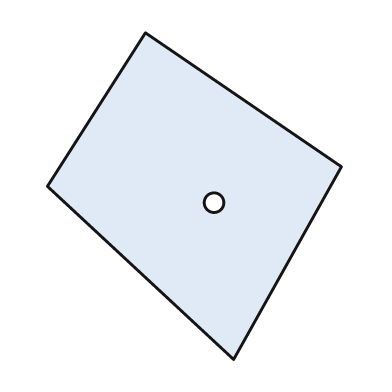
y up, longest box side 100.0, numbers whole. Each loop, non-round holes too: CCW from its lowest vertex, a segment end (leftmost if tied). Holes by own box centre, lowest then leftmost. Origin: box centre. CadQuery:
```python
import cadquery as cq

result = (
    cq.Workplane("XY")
    .moveTo(12.0, -50.0)
    .lineTo(45.0, 9.0)
    .lineTo(-15.0, 50.0)
    .lineTo(-45.0, 3.0)
    .close()
    .moveTo(6.0, -2.0)
    .circle(3.0)
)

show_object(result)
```